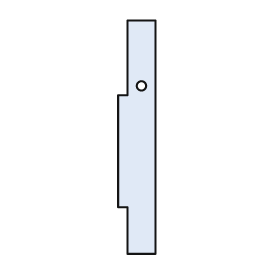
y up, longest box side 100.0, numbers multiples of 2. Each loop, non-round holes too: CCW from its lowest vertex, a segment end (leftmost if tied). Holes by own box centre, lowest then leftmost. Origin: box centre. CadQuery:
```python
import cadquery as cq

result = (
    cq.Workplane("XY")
    .moveTo(-4.0, -50.0)
    .lineTo(8.0, -50.0)
    .lineTo(8.0, 50.0)
    .lineTo(-4.0, 50.0)
    .lineTo(-4.0, 18.0)
    .lineTo(-8.0, 18.0)
    .lineTo(-8.0, -30.0)
    .lineTo(-4.0, -30.0)
    .close()
    .moveTo(2.0, 22.0)
    .circle(2.0)
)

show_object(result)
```